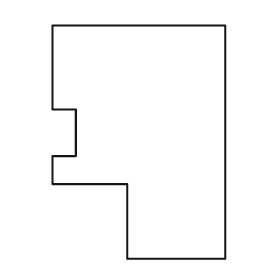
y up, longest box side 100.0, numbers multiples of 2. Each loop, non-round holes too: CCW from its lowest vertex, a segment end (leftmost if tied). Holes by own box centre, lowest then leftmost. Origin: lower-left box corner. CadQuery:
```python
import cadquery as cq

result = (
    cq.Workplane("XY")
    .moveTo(32.0, 0.0)
    .lineTo(74.0, 0.0)
    .lineTo(74.0, 100.0)
    .lineTo(0.0, 100.0)
    .lineTo(0.0, 64.0)
    .lineTo(10.0, 64.0)
    .lineTo(10.0, 44.0)
    .lineTo(0.0, 44.0)
    .lineTo(0.0, 32.0)
    .lineTo(32.0, 32.0)
    .close()
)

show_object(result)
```